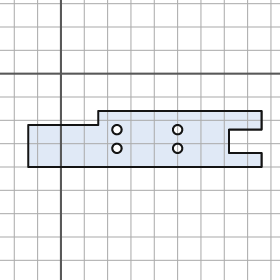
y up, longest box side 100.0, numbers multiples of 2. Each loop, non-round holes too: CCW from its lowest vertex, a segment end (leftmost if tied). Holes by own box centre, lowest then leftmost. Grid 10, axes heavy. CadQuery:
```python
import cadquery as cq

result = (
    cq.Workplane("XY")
    .moveTo(-14.0, -40.0)
    .lineTo(86.0, -40.0)
    .lineTo(86.0, -34.0)
    .lineTo(72.0, -34.0)
    .lineTo(72.0, -24.0)
    .lineTo(86.0, -24.0)
    .lineTo(86.0, -16.0)
    .lineTo(16.0, -16.0)
    .lineTo(16.0, -22.0)
    .lineTo(-14.0, -22.0)
    .close()
    .moveTo(24.0, -32.0)
    .circle(2.0)
    .moveTo(50.0, -32.0)
    .circle(2.0)
    .moveTo(24.0, -24.0)
    .circle(2.0)
    .moveTo(50.0, -24.0)
    .circle(2.0)
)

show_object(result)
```